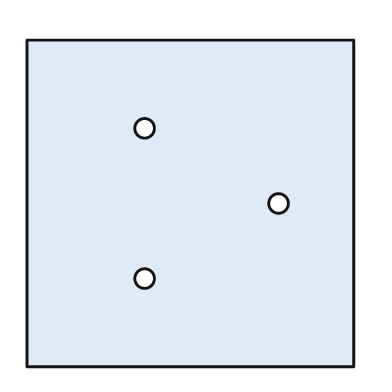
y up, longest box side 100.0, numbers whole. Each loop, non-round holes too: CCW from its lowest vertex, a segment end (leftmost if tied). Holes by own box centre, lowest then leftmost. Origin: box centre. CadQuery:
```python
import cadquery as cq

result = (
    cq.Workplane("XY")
    .moveTo(-50.0, -50.0)
    .lineTo(50.0, -50.0)
    .lineTo(50.0, 50.0)
    .lineTo(-50.0, 50.0)
    .close()
    .moveTo(-14.0, -23.0)
    .circle(3.0)
    .moveTo(27.0, 0.0)
    .circle(3.0)
    .moveTo(-14.0, 23.0)
    .circle(3.0)
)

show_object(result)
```